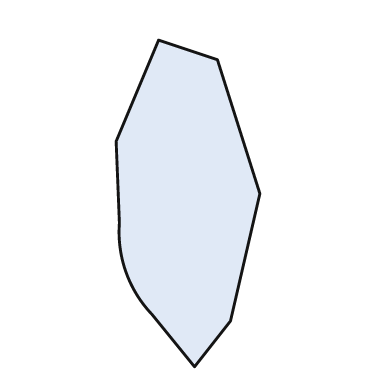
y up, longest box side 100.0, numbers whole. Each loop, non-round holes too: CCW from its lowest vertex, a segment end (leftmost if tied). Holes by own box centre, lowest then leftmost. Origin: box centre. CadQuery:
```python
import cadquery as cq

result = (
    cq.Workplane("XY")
    .moveTo(2.0, -50.0)
    .lineTo(13.0, -36.0)
    .lineTo(22.0, 3.0)
    .lineTo(9.0, 44.0)
    .lineTo(-9.0, 50.0)
    .lineTo(-22.0, 19.0)
    .lineTo(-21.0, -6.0)
    .threePointArc((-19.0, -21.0), (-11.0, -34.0))
    .close()
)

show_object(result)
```